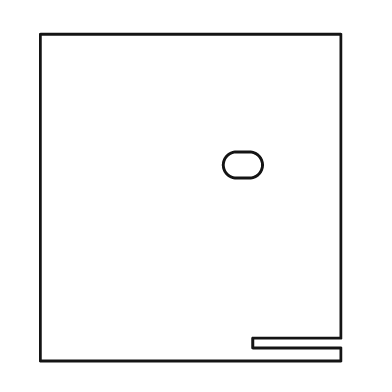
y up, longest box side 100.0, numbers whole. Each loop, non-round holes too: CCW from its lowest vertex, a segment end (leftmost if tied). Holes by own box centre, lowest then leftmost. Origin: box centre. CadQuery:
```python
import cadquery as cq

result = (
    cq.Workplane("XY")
    .moveTo(-46.0, -50.0)
    .lineTo(46.0, -50.0)
    .lineTo(46.0, -46.0)
    .lineTo(19.0, -46.0)
    .lineTo(19.0, -43.0)
    .lineTo(46.0, -43.0)
    .lineTo(46.0, 50.0)
    .lineTo(-46.0, 50.0)
    .close()
    .moveTo(14.0, 6.0)
    .lineTo(18.0, 6.0)
    .threePointArc((22.0, 10.0), (18.0, 14.0))
    .lineTo(14.0, 14.0)
    .threePointArc((10.0, 10.0), (14.0, 6.0))
    .close()
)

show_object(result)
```